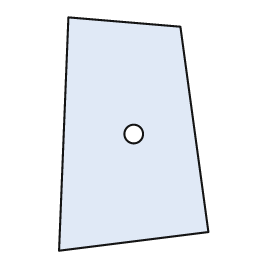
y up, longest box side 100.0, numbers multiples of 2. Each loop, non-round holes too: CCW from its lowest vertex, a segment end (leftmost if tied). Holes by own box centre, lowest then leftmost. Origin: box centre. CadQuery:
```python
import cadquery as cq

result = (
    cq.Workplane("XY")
    .moveTo(-32.0, -50.0)
    .lineTo(32.0, -42.0)
    .lineTo(20.0, 46.0)
    .lineTo(-28.0, 50.0)
    .close()
    .moveTo(0.0, 0.0)
    .circle(4.0)
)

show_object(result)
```